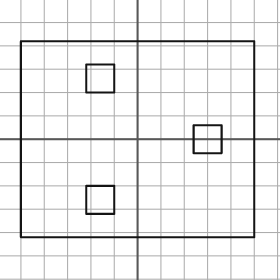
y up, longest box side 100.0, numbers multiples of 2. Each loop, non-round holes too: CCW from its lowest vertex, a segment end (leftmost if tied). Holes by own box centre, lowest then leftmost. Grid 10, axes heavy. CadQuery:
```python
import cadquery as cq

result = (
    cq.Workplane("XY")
    .moveTo(-50.0, -42.0)
    .lineTo(50.0, -42.0)
    .lineTo(50.0, 42.0)
    .lineTo(-50.0, 42.0)
    .close()
    .moveTo(-22.0, -32.0)
    .lineTo(-10.0, -32.0)
    .lineTo(-10.0, -20.0)
    .lineTo(-22.0, -20.0)
    .close()
    .moveTo(24.0, -6.0)
    .lineTo(36.0, -6.0)
    .lineTo(36.0, 6.0)
    .lineTo(24.0, 6.0)
    .close()
    .moveTo(-22.0, 20.0)
    .lineTo(-10.0, 20.0)
    .lineTo(-10.0, 32.0)
    .lineTo(-22.0, 32.0)
    .close()
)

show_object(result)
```